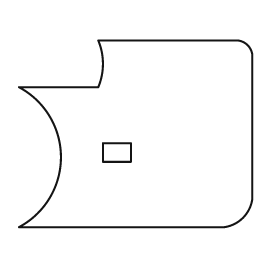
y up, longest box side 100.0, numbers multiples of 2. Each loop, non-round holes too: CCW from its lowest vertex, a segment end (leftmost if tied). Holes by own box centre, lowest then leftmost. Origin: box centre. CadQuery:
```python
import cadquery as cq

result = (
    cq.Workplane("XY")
    .moveTo(-50.0, -40.0)
    .lineTo(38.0, -40.0)
    .threePointArc((46.0, -36.0), (50.0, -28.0))
    .lineTo(50.0, 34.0)
    .threePointArc((48.0, 38.0), (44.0, 40.0))
    .lineTo(-16.0, 40.0)
    .threePointArc((-14.0, 30.0), (-16.0, 20.0))
    .lineTo(-50.0, 20.0)
    .threePointArc((-32.0, -10.0), (-50.0, -40.0))
    .close()
    .moveTo(-14.0, -12.0)
    .lineTo(-2.0, -12.0)
    .lineTo(-2.0, -4.0)
    .lineTo(-14.0, -4.0)
    .close()
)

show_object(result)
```